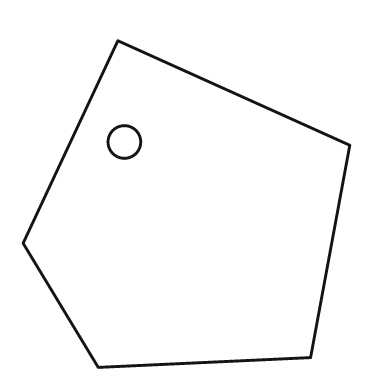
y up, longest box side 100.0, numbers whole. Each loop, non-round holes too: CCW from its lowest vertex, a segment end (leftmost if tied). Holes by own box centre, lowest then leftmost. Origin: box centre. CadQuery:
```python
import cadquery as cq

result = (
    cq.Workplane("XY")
    .moveTo(-27.0, -50.0)
    .lineTo(38.0, -47.0)
    .lineTo(50.0, 18.0)
    .lineTo(-21.0, 50.0)
    .lineTo(-50.0, -12.0)
    .close()
    .moveTo(-19.0, 19.0)
    .circle(5.0)
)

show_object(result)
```